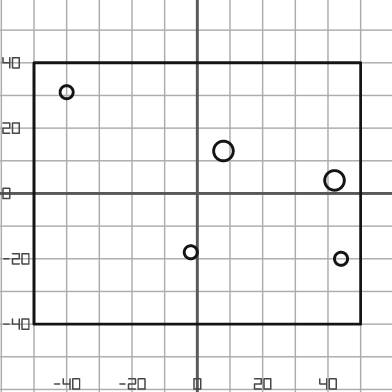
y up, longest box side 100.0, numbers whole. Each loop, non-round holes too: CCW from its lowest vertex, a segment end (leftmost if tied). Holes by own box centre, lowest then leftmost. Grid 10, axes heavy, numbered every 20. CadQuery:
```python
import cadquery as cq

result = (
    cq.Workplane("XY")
    .moveTo(-50.0, -40.0)
    .lineTo(50.0, -40.0)
    .lineTo(50.0, 40.0)
    .lineTo(-50.0, 40.0)
    .close()
    .moveTo(44.0, -20.0)
    .circle(2.0)
    .moveTo(-2.0, -18.0)
    .circle(2.0)
    .moveTo(42.0, 4.0)
    .circle(3.0)
    .moveTo(8.0, 13.0)
    .circle(3.0)
    .moveTo(-40.0, 31.0)
    .circle(2.0)
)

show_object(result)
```